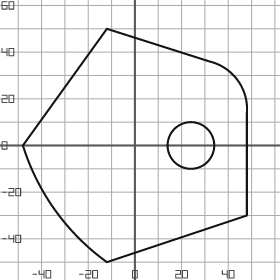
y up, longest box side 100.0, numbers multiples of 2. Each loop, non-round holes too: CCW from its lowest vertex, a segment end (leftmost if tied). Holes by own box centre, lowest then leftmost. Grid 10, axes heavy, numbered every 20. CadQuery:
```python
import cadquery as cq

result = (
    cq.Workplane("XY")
    .moveTo(-12.0, -50.0)
    .lineTo(48.0, -30.0)
    .lineTo(48.0, 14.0)
    .threePointArc((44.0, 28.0), (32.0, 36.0))
    .lineTo(-12.0, 50.0)
    .lineTo(-48.0, 0.0)
    .threePointArc((-34.0, -28.0), (-12.0, -50.0))
    .close()
    .moveTo(24.0, 0.0)
    .circle(10.0)
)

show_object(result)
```